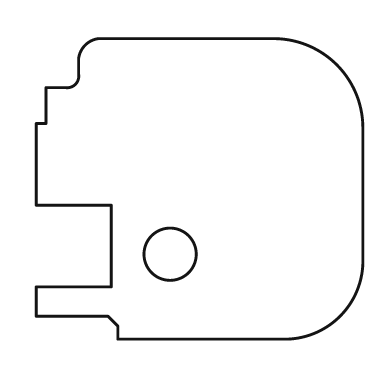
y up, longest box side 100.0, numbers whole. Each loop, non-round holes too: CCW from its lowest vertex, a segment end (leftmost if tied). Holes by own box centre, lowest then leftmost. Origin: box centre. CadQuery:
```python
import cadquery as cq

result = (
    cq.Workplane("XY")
    .moveTo(-25.0, -46.0)
    .lineTo(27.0, -46.0)
    .threePointArc((43.0, -39.0), (50.0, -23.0))
    .lineTo(50.0, 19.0)
    .threePointArc((42.0, 38.0), (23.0, 46.0))
    .lineTo(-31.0, 46.0)
    .threePointArc((-35.0, 44.0), (-37.0, 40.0))
    .lineTo(-37.0, 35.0)
    .threePointArc((-38.0, 32.0), (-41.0, 31.0))
    .lineTo(-47.0, 31.0)
    .lineTo(-47.0, 20.0)
    .lineTo(-50.0, 20.0)
    .lineTo(-50.0, -5.0)
    .lineTo(-27.0, -5.0)
    .lineTo(-27.0, -30.0)
    .lineTo(-50.0, -30.0)
    .lineTo(-50.0, -39.0)
    .lineTo(-28.0, -39.0)
    .lineTo(-25.0, -42.0)
    .close()
    .moveTo(-9.0, -20.0)
    .circle(8.0)
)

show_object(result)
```